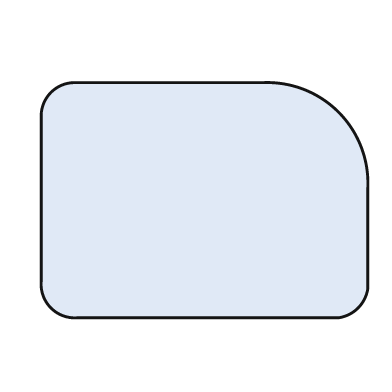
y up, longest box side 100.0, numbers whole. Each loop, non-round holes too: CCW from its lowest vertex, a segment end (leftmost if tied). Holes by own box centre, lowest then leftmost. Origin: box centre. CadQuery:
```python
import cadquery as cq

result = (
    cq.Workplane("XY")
    .moveTo(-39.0, -36.0)
    .lineTo(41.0, -36.0)
    .threePointArc((47.0, -33.0), (50.0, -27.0))
    .lineTo(50.0, 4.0)
    .threePointArc((41.0, 27.0), (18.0, 36.0))
    .lineTo(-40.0, 36.0)
    .threePointArc((-47.0, 33.0), (-50.0, 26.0))
    .lineTo(-50.0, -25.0)
    .threePointArc((-47.0, -33.0), (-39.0, -36.0))
    .close()
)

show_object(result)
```